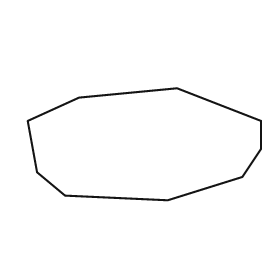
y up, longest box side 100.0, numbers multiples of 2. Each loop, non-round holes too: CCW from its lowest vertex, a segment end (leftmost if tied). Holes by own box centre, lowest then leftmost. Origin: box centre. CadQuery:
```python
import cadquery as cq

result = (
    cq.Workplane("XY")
    .moveTo(10.0, -24.0)
    .lineTo(42.0, -14.0)
    .lineTo(50.0, -2.0)
    .lineTo(50.0, 10.0)
    .lineTo(14.0, 24.0)
    .lineTo(-28.0, 20.0)
    .lineTo(-50.0, 10.0)
    .lineTo(-46.0, -12.0)
    .lineTo(-34.0, -22.0)
    .close()
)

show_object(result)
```